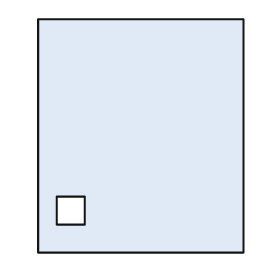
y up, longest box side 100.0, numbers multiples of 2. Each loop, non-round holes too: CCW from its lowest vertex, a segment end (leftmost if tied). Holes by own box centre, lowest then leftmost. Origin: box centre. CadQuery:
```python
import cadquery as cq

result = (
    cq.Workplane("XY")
    .moveTo(-44.0, -50.0)
    .lineTo(44.0, -50.0)
    .lineTo(44.0, 50.0)
    .lineTo(-44.0, 50.0)
    .close()
    .moveTo(-36.0, -38.0)
    .lineTo(-24.0, -38.0)
    .lineTo(-24.0, -26.0)
    .lineTo(-36.0, -26.0)
    .close()
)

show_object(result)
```